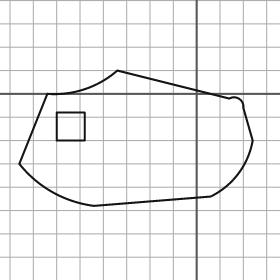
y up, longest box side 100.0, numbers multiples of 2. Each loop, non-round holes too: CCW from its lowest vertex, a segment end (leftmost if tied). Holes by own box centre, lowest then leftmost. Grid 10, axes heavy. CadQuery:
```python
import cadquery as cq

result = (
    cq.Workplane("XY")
    .moveTo(-44.0, -48.0)
    .lineTo(6.0, -44.0)
    .threePointArc((18.0, -34.0), (24.0, -20.0))
    .lineTo(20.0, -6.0)
    .threePointArc((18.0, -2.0), (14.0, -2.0))
    .lineTo(-34.0, 10.0)
    .threePointArc((-48.0, 2.0), (-64.0, 0.0))
    .lineTo(-76.0, -30.0)
    .threePointArc((-62.0, -42.0), (-44.0, -48.0))
    .close()
    .moveTo(-60.0, -20.0)
    .lineTo(-48.0, -20.0)
    .lineTo(-48.0, -8.0)
    .lineTo(-60.0, -8.0)
    .close()
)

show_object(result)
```